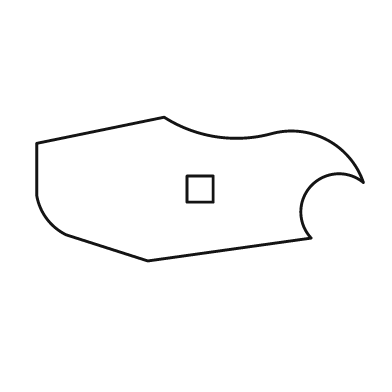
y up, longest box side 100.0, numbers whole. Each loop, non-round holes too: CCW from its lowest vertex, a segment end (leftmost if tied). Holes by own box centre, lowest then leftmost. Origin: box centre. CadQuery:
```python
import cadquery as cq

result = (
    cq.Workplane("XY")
    .moveTo(-16.0, -22.0)
    .lineTo(34.0, -15.0)
    .threePointArc((34.0, 1.0), (50.0, 2.0))
    .threePointArc((39.0, 15.0), (22.0, 17.0))
    .threePointArc((5.0, 16.0), (-11.0, 22.0))
    .lineTo(-50.0, 14.0)
    .lineTo(-50.0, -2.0)
    .threePointArc((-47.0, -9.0), (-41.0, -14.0))
    .close()
    .moveTo(-4.0, -4.0)
    .lineTo(4.0, -4.0)
    .lineTo(4.0, 4.0)
    .lineTo(-4.0, 4.0)
    .close()
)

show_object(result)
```